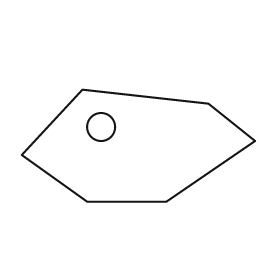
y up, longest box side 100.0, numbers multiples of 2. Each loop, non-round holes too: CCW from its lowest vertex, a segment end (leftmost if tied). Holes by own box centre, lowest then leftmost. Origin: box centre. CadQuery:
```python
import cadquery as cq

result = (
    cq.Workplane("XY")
    .moveTo(-22.0, -24.0)
    .lineTo(12.0, -24.0)
    .lineTo(50.0, 2.0)
    .lineTo(30.0, 18.0)
    .lineTo(-24.0, 24.0)
    .lineTo(-50.0, -4.0)
    .close()
    .moveTo(-16.0, 8.0)
    .circle(6.0)
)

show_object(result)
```